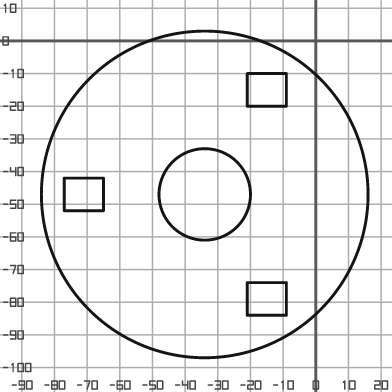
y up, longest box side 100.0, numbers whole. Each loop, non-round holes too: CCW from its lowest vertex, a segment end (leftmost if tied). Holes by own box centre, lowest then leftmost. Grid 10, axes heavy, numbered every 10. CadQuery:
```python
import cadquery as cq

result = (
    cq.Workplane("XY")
    .moveTo(-34.0, -47.0)
    .circle(50.0)
    .moveTo(-21.0, -84.0)
    .lineTo(-9.0, -84.0)
    .lineTo(-9.0, -74.0)
    .lineTo(-21.0, -74.0)
    .close()
    .moveTo(-77.0, -52.0)
    .lineTo(-65.0, -52.0)
    .lineTo(-65.0, -42.0)
    .lineTo(-77.0, -42.0)
    .close()
    .moveTo(-34.0, -47.0)
    .circle(14.0)
    .moveTo(-21.0, -20.0)
    .lineTo(-9.0, -20.0)
    .lineTo(-9.0, -10.0)
    .lineTo(-21.0, -10.0)
    .close()
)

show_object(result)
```